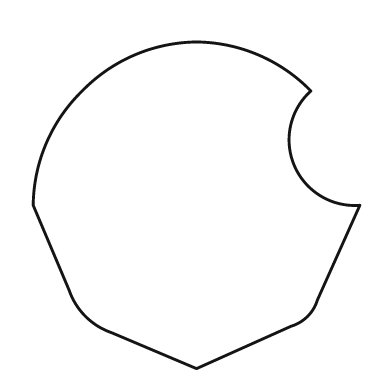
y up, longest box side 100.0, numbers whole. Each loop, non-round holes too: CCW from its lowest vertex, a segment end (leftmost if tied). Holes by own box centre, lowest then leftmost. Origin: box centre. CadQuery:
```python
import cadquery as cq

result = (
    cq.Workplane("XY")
    .moveTo(0.0, -50.0)
    .lineTo(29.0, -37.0)
    .threePointArc((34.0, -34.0), (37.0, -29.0))
    .lineTo(50.0, 0.0)
    .threePointArc((30.0, 12.0), (35.0, 35.0))
    .threePointArc((19.0, 46.0), (0.0, 50.0))
    .threePointArc((-19.0, 46.0), (-35.0, 35.0))
    .threePointArc((-46.0, 19.0), (-50.0, 0.0))
    .lineTo(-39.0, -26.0)
    .threePointArc((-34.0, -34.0), (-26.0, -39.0))
    .close()
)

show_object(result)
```